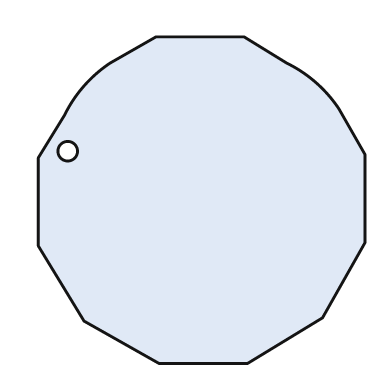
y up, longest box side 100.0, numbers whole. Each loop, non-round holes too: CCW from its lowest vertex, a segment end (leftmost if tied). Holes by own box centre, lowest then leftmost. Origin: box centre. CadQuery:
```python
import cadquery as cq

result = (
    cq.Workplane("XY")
    .moveTo(-13.0, -50.0)
    .lineTo(14.0, -50.0)
    .lineTo(37.0, -36.0)
    .lineTo(50.0, -13.0)
    .lineTo(50.0, 14.0)
    .lineTo(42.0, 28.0)
    .threePointArc((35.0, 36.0), (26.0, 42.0))
    .lineTo(13.0, 50.0)
    .lineTo(-14.0, 50.0)
    .lineTo(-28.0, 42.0)
    .threePointArc((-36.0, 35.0), (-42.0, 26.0))
    .lineTo(-50.0, 13.0)
    .lineTo(-50.0, -14.0)
    .lineTo(-36.0, -37.0)
    .close()
    .moveTo(-41.0, 15.0)
    .circle(3.0)
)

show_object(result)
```